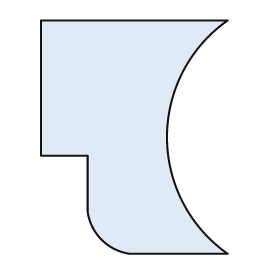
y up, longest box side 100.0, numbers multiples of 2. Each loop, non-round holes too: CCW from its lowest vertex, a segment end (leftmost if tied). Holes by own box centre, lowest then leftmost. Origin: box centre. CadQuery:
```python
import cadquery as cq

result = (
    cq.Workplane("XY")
    .moveTo(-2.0, -50.0)
    .lineTo(40.0, -50.0)
    .threePointArc((14.0, 0.0), (40.0, 50.0))
    .lineTo(-40.0, 50.0)
    .lineTo(-40.0, -8.0)
    .lineTo(-20.0, -8.0)
    .lineTo(-20.0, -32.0)
    .threePointArc((-14.0, -44.0), (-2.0, -50.0))
    .close()
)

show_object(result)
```